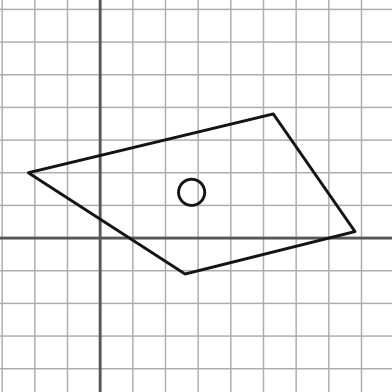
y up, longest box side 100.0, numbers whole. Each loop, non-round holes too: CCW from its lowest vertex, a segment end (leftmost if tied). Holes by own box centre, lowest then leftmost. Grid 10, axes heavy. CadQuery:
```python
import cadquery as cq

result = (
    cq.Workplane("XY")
    .moveTo(26.0, -11.0)
    .lineTo(78.0, 2.0)
    .lineTo(53.0, 38.0)
    .lineTo(-22.0, 20.0)
    .close()
    .moveTo(28.0, 14.0)
    .circle(4.0)
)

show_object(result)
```